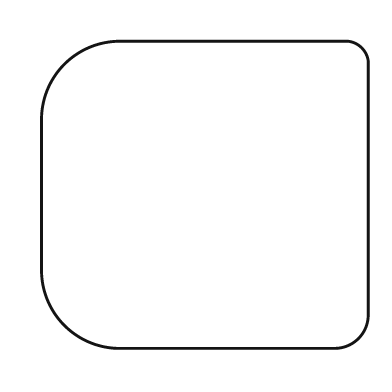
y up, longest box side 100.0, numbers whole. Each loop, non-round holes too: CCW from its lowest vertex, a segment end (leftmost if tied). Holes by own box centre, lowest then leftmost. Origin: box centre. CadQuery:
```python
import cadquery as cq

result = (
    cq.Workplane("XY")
    .moveTo(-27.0, -47.0)
    .lineTo(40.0, -47.0)
    .threePointArc((47.0, -44.0), (50.0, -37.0))
    .lineTo(50.0, 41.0)
    .threePointArc((48.0, 45.0), (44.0, 47.0))
    .lineTo(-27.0, 47.0)
    .threePointArc((-43.0, 40.0), (-50.0, 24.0))
    .lineTo(-50.0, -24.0)
    .threePointArc((-43.0, -40.0), (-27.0, -47.0))
    .close()
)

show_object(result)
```